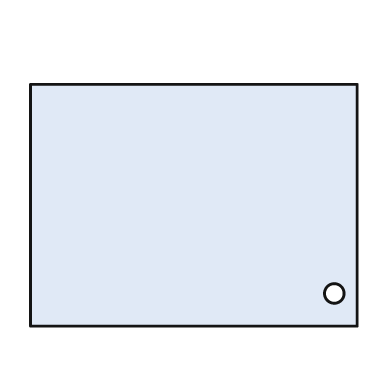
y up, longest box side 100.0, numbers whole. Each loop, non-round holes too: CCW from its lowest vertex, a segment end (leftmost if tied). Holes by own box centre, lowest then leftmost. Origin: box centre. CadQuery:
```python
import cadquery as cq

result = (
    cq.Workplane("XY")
    .moveTo(-50.0, -37.0)
    .lineTo(50.0, -37.0)
    .lineTo(50.0, 37.0)
    .lineTo(-50.0, 37.0)
    .close()
    .moveTo(43.0, -27.0)
    .circle(3.0)
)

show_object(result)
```